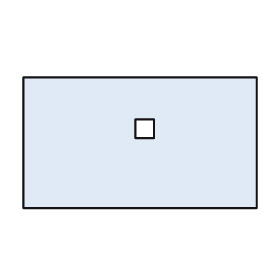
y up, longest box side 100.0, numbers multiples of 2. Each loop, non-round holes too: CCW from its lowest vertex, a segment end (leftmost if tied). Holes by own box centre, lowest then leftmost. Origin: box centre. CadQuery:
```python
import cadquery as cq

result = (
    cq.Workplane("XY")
    .moveTo(-50.0, -28.0)
    .lineTo(50.0, -28.0)
    .lineTo(50.0, 28.0)
    .lineTo(-50.0, 28.0)
    .close()
    .moveTo(-2.0, 2.0)
    .lineTo(6.0, 2.0)
    .lineTo(6.0, 10.0)
    .lineTo(-2.0, 10.0)
    .close()
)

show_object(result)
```